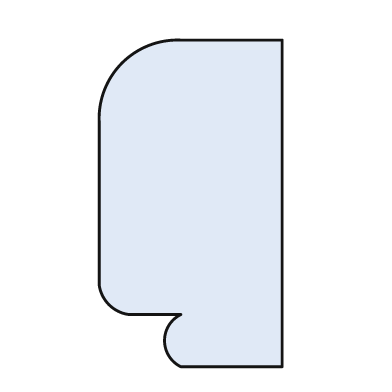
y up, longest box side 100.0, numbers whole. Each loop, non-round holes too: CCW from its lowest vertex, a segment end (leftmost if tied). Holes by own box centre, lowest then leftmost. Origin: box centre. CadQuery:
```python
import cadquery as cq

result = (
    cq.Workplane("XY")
    .moveTo(-3.0, -50.0)
    .lineTo(28.0, -50.0)
    .lineTo(28.0, 50.0)
    .lineTo(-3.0, 50.0)
    .threePointArc((-21.0, 43.0), (-28.0, 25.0))
    .lineTo(-28.0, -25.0)
    .threePointArc((-25.0, -31.0), (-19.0, -34.0))
    .lineTo(-3.0, -34.0)
    .threePointArc((-8.0, -42.0), (-3.0, -50.0))
    .close()
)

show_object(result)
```